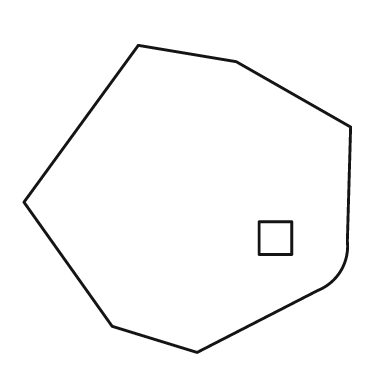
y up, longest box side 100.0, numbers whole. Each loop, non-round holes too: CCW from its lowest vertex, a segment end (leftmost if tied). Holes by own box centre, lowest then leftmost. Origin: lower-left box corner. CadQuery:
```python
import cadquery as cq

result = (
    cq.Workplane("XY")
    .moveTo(53.0, 0.0)
    .lineTo(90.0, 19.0)
    .threePointArc((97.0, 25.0), (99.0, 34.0))
    .lineTo(100.0, 69.0)
    .lineTo(65.0, 89.0)
    .lineTo(35.0, 94.0)
    .lineTo(0.0, 46.0)
    .lineTo(27.0, 8.0)
    .close()
    .moveTo(72.0, 30.0)
    .lineTo(82.0, 30.0)
    .lineTo(82.0, 40.0)
    .lineTo(72.0, 40.0)
    .close()
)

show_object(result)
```